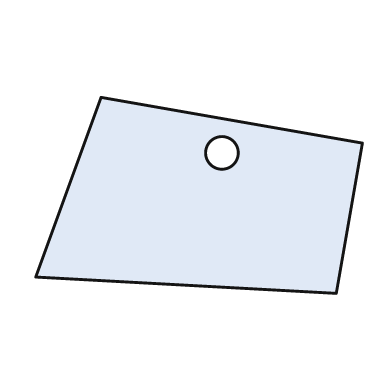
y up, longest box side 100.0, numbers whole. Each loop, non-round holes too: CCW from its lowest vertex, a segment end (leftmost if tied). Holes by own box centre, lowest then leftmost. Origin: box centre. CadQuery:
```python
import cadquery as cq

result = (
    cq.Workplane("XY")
    .moveTo(42.0, -30.0)
    .lineTo(50.0, 16.0)
    .lineTo(-30.0, 30.0)
    .lineTo(-50.0, -25.0)
    .close()
    .moveTo(7.0, 13.0)
    .circle(5.0)
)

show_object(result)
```